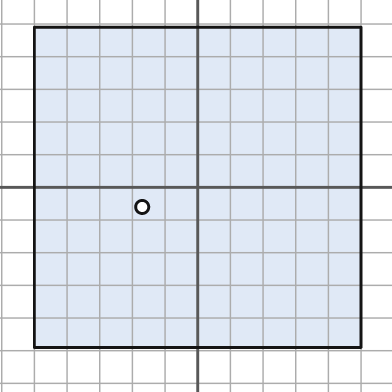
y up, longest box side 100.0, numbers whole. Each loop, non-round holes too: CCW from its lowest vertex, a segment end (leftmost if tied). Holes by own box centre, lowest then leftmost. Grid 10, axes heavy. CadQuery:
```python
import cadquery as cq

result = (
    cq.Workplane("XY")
    .moveTo(-50.0, -49.0)
    .lineTo(50.0, -49.0)
    .lineTo(50.0, 49.0)
    .lineTo(-50.0, 49.0)
    .close()
    .moveTo(-17.0, -6.0)
    .circle(2.0)
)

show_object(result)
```